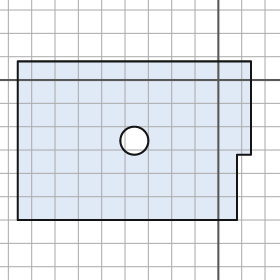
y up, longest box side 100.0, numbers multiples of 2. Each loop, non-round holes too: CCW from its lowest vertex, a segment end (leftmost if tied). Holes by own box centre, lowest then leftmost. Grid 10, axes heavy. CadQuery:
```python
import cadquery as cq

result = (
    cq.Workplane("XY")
    .moveTo(-86.0, -60.0)
    .lineTo(8.0, -60.0)
    .lineTo(8.0, -32.0)
    .lineTo(14.0, -32.0)
    .lineTo(14.0, 8.0)
    .lineTo(-86.0, 8.0)
    .close()
    .moveTo(-36.0, -26.0)
    .circle(6.0)
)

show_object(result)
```